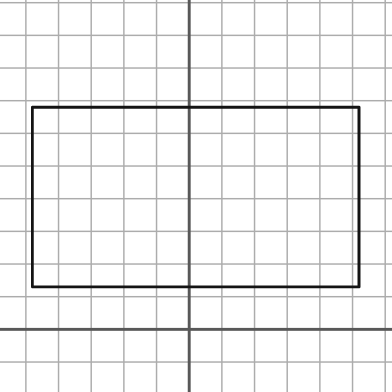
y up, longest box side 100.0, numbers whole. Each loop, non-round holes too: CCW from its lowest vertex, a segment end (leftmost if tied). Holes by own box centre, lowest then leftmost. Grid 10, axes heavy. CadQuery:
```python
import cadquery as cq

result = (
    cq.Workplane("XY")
    .moveTo(-48.0, 13.0)
    .lineTo(52.0, 13.0)
    .lineTo(52.0, 68.0)
    .lineTo(-48.0, 68.0)
    .close()
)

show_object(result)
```